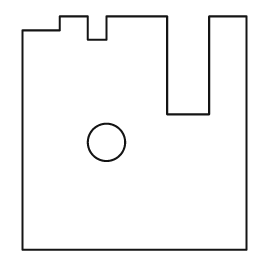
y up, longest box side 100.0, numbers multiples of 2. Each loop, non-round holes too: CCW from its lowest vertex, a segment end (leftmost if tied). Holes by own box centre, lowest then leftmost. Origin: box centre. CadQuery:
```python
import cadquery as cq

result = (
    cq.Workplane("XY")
    .moveTo(-48.0, -50.0)
    .lineTo(48.0, -50.0)
    .lineTo(48.0, 50.0)
    .lineTo(32.0, 50.0)
    .lineTo(32.0, 8.0)
    .lineTo(14.0, 8.0)
    .lineTo(14.0, 50.0)
    .lineTo(-12.0, 50.0)
    .lineTo(-12.0, 40.0)
    .lineTo(-20.0, 40.0)
    .lineTo(-20.0, 50.0)
    .lineTo(-32.0, 50.0)
    .lineTo(-32.0, 44.0)
    .lineTo(-48.0, 44.0)
    .close()
    .moveTo(-12.0, -4.0)
    .circle(8.0)
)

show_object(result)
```